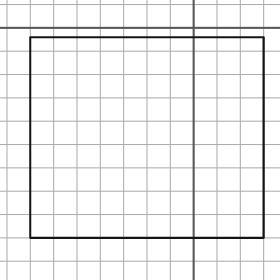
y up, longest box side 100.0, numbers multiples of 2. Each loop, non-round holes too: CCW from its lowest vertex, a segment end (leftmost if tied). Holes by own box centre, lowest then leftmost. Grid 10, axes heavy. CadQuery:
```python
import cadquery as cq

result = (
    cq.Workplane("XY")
    .moveTo(-70.0, -90.0)
    .lineTo(30.0, -90.0)
    .lineTo(30.0, -4.0)
    .lineTo(-70.0, -4.0)
    .close()
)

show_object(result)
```